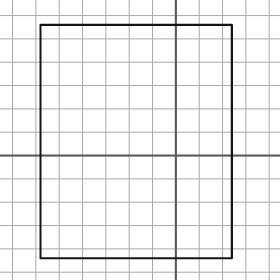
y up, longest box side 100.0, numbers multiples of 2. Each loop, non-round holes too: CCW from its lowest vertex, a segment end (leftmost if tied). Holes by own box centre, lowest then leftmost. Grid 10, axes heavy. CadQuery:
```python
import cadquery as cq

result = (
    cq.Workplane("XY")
    .moveTo(-58.0, -44.0)
    .lineTo(24.0, -44.0)
    .lineTo(24.0, 56.0)
    .lineTo(-58.0, 56.0)
    .close()
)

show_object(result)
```